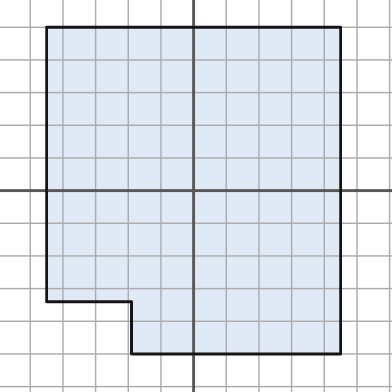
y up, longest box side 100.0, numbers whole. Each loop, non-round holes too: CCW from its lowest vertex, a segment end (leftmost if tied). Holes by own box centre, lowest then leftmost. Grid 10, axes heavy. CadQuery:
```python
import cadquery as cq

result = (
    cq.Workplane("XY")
    .moveTo(-19.0, -50.0)
    .lineTo(45.0, -50.0)
    .lineTo(45.0, 50.0)
    .lineTo(-45.0, 50.0)
    .lineTo(-45.0, -34.0)
    .lineTo(-19.0, -34.0)
    .close()
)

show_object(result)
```